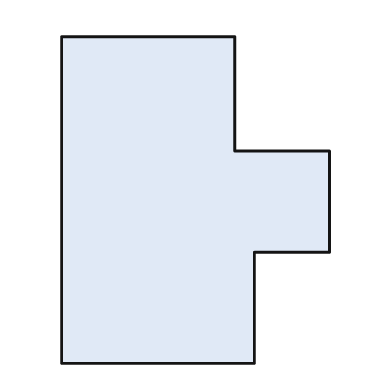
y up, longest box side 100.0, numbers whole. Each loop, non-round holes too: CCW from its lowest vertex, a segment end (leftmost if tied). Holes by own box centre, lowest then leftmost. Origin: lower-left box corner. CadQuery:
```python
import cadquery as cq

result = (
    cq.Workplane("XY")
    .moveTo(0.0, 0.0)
    .lineTo(59.0, 0.0)
    .lineTo(59.0, 34.0)
    .lineTo(82.0, 34.0)
    .lineTo(82.0, 65.0)
    .lineTo(53.0, 65.0)
    .lineTo(53.0, 100.0)
    .lineTo(0.0, 100.0)
    .close()
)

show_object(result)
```